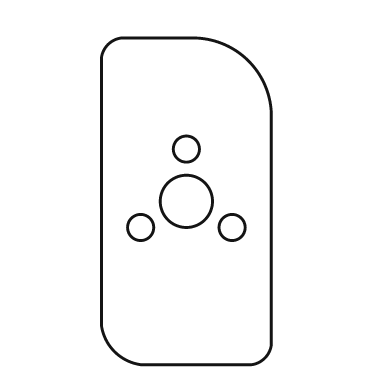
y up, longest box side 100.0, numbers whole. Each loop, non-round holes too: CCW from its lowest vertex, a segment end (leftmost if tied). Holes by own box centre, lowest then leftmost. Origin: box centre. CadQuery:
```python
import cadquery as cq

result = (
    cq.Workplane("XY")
    .moveTo(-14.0, -50.0)
    .lineTo(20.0, -50.0)
    .threePointArc((24.0, -48.0), (26.0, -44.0))
    .lineTo(26.0, 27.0)
    .threePointArc((19.0, 43.0), (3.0, 50.0))
    .lineTo(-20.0, 50.0)
    .threePointArc((-24.0, 48.0), (-26.0, 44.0))
    .lineTo(-26.0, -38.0)
    .threePointArc((-22.0, -46.0), (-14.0, -50.0))
    .close()
    .moveTo(-14.0, -8.0)
    .circle(4.0)
    .moveTo(14.0, -8.0)
    .circle(4.0)
    .moveTo(0.0, 0.0)
    .circle(8.0)
    .moveTo(0.0, 16.0)
    .circle(4.0)
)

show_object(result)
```